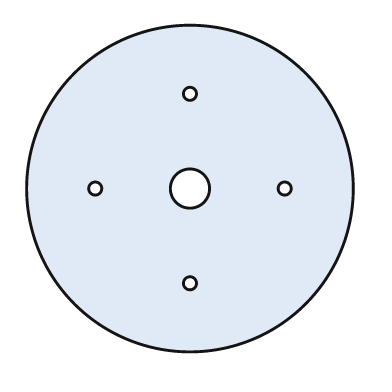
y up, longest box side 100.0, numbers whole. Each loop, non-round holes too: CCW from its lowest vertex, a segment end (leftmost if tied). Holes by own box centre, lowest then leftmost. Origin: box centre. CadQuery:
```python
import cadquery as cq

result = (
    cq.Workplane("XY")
    .moveTo(0.0, 0.0)
    .circle(50.0)
    .moveTo(0.0, -29.0)
    .circle(2.0)
    .moveTo(-29.0, 0.0)
    .circle(2.0)
    .moveTo(0.0, 0.0)
    .circle(6.0)
    .moveTo(29.0, 0.0)
    .circle(2.0)
    .moveTo(0.0, 29.0)
    .circle(2.0)
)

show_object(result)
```